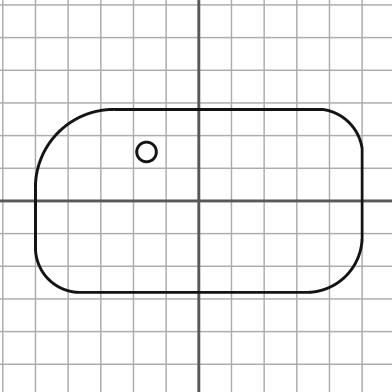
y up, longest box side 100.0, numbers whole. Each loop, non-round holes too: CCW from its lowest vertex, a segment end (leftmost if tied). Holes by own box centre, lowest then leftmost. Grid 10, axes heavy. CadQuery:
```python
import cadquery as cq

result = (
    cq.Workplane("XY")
    .moveTo(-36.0, -28.0)
    .lineTo(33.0, -28.0)
    .threePointArc((45.0, -23.0), (50.0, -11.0))
    .lineTo(50.0, 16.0)
    .threePointArc((46.0, 24.0), (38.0, 28.0))
    .lineTo(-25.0, 28.0)
    .threePointArc((-43.0, 21.0), (-50.0, 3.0))
    .lineTo(-50.0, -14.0)
    .threePointArc((-46.0, -24.0), (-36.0, -28.0))
    .close()
    .moveTo(-16.0, 15.0)
    .circle(3.0)
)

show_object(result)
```